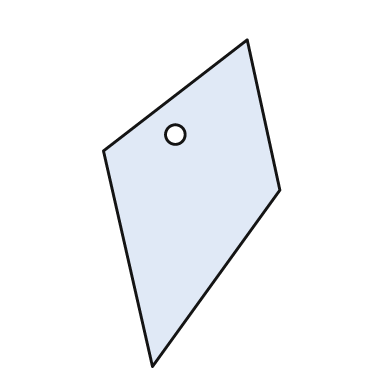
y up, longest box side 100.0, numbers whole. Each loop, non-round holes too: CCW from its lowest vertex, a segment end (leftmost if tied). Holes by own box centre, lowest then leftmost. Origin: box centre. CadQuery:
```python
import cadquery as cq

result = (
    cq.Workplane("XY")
    .moveTo(-12.0, -50.0)
    .lineTo(27.0, 4.0)
    .lineTo(17.0, 50.0)
    .lineTo(-27.0, 16.0)
    .close()
    .moveTo(-5.0, 21.0)
    .circle(3.0)
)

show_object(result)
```